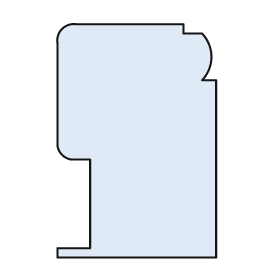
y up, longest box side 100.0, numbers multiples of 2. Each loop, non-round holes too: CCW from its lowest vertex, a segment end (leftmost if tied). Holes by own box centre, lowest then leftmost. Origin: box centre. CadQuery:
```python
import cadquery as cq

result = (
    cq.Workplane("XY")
    .moveTo(-34.0, -50.0)
    .lineTo(34.0, -50.0)
    .lineTo(34.0, 26.0)
    .lineTo(28.0, 26.0)
    .threePointArc((32.0, 36.0), (28.0, 46.0))
    .lineTo(20.0, 46.0)
    .lineTo(20.0, 50.0)
    .lineTo(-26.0, 50.0)
    .threePointArc((-32.0, 48.0), (-34.0, 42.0))
    .lineTo(-34.0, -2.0)
    .threePointArc((-32.0, -6.0), (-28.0, -8.0))
    .lineTo(-20.0, -8.0)
    .lineTo(-20.0, -46.0)
    .lineTo(-34.0, -46.0)
    .close()
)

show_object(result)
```